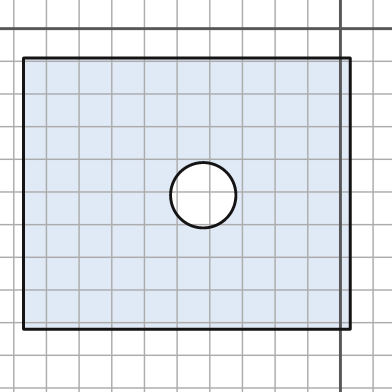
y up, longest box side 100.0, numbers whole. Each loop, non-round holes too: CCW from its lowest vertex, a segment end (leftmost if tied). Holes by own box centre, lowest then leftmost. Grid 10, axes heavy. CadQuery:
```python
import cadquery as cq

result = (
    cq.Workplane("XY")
    .moveTo(-97.0, -92.0)
    .lineTo(3.0, -92.0)
    .lineTo(3.0, -9.0)
    .lineTo(-97.0, -9.0)
    .close()
    .moveTo(-42.0, -51.0)
    .circle(10.0)
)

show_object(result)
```